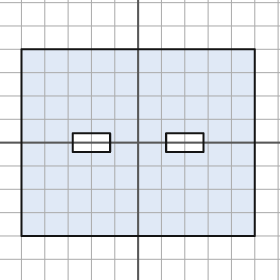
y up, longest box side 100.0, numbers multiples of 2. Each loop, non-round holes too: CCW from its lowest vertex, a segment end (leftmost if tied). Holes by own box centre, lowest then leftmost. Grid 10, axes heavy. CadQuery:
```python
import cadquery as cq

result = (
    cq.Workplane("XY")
    .moveTo(-50.0, -40.0)
    .lineTo(50.0, -40.0)
    .lineTo(50.0, 40.0)
    .lineTo(-50.0, 40.0)
    .close()
    .moveTo(-28.0, -4.0)
    .lineTo(-12.0, -4.0)
    .lineTo(-12.0, 4.0)
    .lineTo(-28.0, 4.0)
    .close()
    .moveTo(12.0, -4.0)
    .lineTo(28.0, -4.0)
    .lineTo(28.0, 4.0)
    .lineTo(12.0, 4.0)
    .close()
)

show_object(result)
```